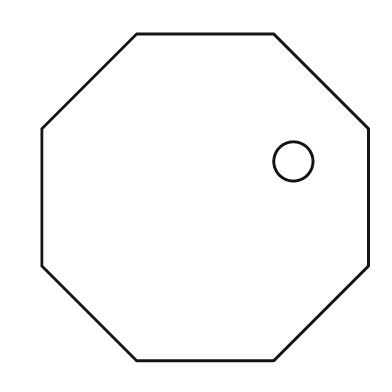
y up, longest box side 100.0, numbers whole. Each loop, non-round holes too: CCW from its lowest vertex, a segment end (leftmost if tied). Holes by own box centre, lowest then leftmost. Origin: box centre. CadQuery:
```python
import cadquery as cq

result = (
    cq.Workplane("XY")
    .moveTo(-21.0, -50.0)
    .lineTo(21.0, -50.0)
    .lineTo(50.0, -21.0)
    .lineTo(50.0, 21.0)
    .lineTo(21.0, 50.0)
    .lineTo(-21.0, 50.0)
    .lineTo(-50.0, 21.0)
    .lineTo(-50.0, -21.0)
    .close()
    .moveTo(27.0, 11.0)
    .circle(6.0)
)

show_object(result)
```